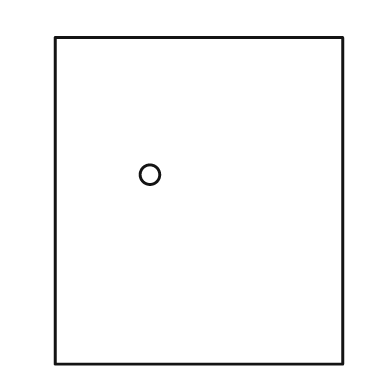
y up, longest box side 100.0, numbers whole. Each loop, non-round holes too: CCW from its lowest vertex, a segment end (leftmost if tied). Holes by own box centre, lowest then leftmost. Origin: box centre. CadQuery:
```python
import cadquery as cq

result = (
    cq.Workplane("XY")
    .moveTo(-44.0, -50.0)
    .lineTo(44.0, -50.0)
    .lineTo(44.0, 50.0)
    .lineTo(-44.0, 50.0)
    .close()
    .moveTo(-15.0, 8.0)
    .circle(3.0)
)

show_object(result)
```